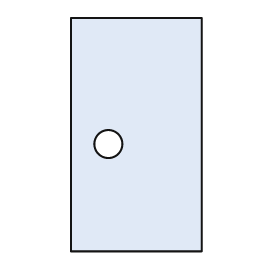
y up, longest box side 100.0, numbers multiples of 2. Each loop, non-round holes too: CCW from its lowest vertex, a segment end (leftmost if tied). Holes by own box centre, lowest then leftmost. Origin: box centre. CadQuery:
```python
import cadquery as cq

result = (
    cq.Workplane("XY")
    .moveTo(-28.0, -50.0)
    .lineTo(28.0, -50.0)
    .lineTo(28.0, 50.0)
    .lineTo(-28.0, 50.0)
    .close()
    .moveTo(-12.0, -4.0)
    .circle(6.0)
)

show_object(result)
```